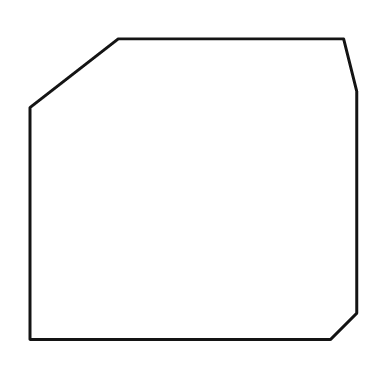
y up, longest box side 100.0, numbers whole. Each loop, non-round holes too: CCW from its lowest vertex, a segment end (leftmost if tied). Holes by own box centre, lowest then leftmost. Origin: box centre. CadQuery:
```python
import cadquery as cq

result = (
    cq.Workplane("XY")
    .moveTo(-50.0, -46.0)
    .lineTo(42.0, -46.0)
    .lineTo(50.0, -38.0)
    .lineTo(50.0, 30.0)
    .lineTo(46.0, 46.0)
    .lineTo(-23.0, 46.0)
    .lineTo(-50.0, 25.0)
    .close()
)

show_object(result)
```